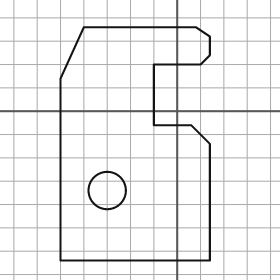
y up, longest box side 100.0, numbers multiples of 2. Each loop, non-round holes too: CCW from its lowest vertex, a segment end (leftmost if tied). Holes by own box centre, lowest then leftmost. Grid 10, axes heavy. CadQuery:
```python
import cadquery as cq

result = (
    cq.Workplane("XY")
    .moveTo(-50.0, -64.0)
    .lineTo(14.0, -64.0)
    .lineTo(14.0, -14.0)
    .lineTo(6.0, -6.0)
    .lineTo(-10.0, -6.0)
    .lineTo(-10.0, 20.0)
    .lineTo(10.0, 20.0)
    .lineTo(14.0, 24.0)
    .lineTo(14.0, 32.0)
    .lineTo(8.0, 36.0)
    .lineTo(-40.0, 36.0)
    .lineTo(-50.0, 14.0)
    .close()
    .moveTo(-30.0, -34.0)
    .circle(8.0)
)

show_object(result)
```